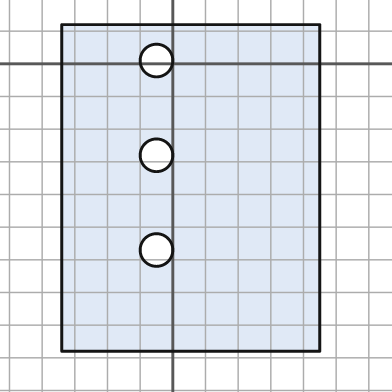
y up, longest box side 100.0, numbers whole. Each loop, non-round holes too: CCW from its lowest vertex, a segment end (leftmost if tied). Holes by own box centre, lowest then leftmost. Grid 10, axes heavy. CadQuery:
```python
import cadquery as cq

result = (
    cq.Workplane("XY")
    .moveTo(-34.0, -88.0)
    .lineTo(45.0, -88.0)
    .lineTo(45.0, 12.0)
    .lineTo(-34.0, 12.0)
    .close()
    .moveTo(-5.0, -57.0)
    .circle(5.0)
    .moveTo(-5.0, -28.0)
    .circle(5.0)
    .moveTo(-5.0, 1.0)
    .circle(5.0)
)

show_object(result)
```